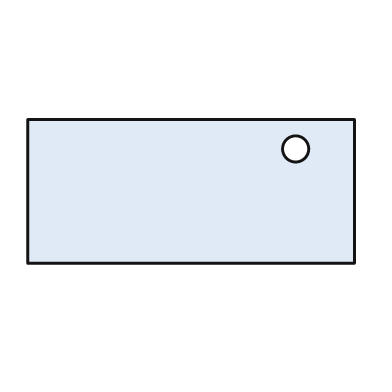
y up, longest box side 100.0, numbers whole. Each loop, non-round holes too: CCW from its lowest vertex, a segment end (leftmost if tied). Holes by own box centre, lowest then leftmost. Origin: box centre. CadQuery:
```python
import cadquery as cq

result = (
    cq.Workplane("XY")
    .moveTo(-50.0, -22.0)
    .lineTo(50.0, -22.0)
    .lineTo(50.0, 22.0)
    .lineTo(-50.0, 22.0)
    .close()
    .moveTo(32.0, 13.0)
    .circle(4.0)
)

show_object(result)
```